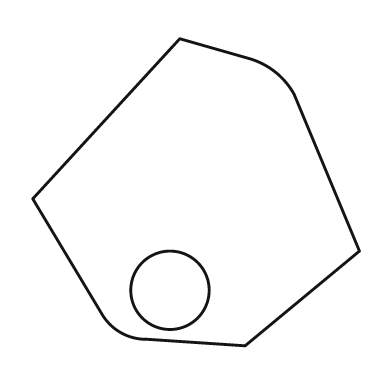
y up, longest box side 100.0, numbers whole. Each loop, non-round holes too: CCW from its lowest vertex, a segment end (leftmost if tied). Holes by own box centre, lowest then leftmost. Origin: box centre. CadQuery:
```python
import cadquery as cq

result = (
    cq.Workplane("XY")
    .moveTo(15.0, -47.0)
    .lineTo(50.0, -18.0)
    .lineTo(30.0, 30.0)
    .threePointArc((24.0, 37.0), (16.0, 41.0))
    .lineTo(-5.0, 47.0)
    .lineTo(-50.0, -2.0)
    .lineTo(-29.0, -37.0)
    .threePointArc((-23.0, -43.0), (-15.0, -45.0))
    .close()
    .moveTo(-8.0, -30.0)
    .circle(12.0)
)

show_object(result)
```